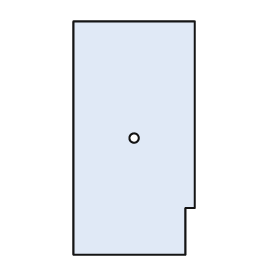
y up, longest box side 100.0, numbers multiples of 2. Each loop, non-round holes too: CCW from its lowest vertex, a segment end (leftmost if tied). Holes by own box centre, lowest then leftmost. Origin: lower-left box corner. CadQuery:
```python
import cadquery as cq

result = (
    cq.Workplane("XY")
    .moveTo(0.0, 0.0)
    .lineTo(48.0, 0.0)
    .lineTo(48.0, 20.0)
    .lineTo(52.0, 20.0)
    .lineTo(52.0, 100.0)
    .lineTo(0.0, 100.0)
    .close()
    .moveTo(26.0, 50.0)
    .circle(2.0)
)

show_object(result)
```